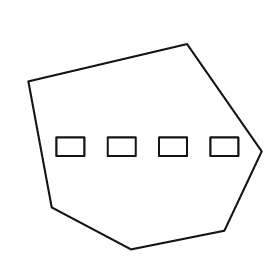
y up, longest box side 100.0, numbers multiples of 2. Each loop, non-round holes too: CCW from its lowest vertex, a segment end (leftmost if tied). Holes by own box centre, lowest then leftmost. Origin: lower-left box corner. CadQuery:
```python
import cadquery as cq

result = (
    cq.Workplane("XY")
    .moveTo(44.0, 0.0)
    .lineTo(84.0, 8.0)
    .lineTo(100.0, 42.0)
    .lineTo(68.0, 88.0)
    .lineTo(0.0, 72.0)
    .lineTo(10.0, 18.0)
    .close()
    .moveTo(12.0, 40.0)
    .lineTo(24.0, 40.0)
    .lineTo(24.0, 48.0)
    .lineTo(12.0, 48.0)
    .close()
    .moveTo(34.0, 40.0)
    .lineTo(46.0, 40.0)
    .lineTo(46.0, 48.0)
    .lineTo(34.0, 48.0)
    .close()
    .moveTo(56.0, 40.0)
    .lineTo(68.0, 40.0)
    .lineTo(68.0, 48.0)
    .lineTo(56.0, 48.0)
    .close()
    .moveTo(78.0, 40.0)
    .lineTo(90.0, 40.0)
    .lineTo(90.0, 48.0)
    .lineTo(78.0, 48.0)
    .close()
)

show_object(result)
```